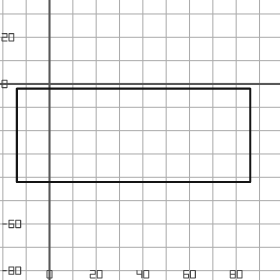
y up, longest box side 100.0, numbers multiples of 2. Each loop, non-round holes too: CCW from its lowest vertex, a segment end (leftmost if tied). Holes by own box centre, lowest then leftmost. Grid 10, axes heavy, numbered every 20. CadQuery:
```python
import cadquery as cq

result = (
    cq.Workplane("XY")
    .moveTo(-14.0, -42.0)
    .lineTo(86.0, -42.0)
    .lineTo(86.0, -2.0)
    .lineTo(-14.0, -2.0)
    .close()
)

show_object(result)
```